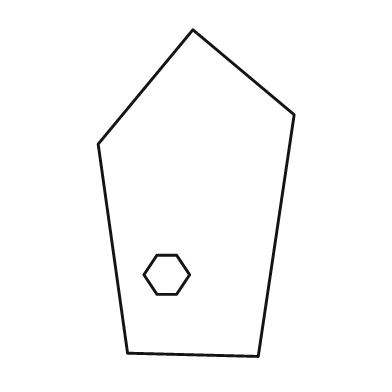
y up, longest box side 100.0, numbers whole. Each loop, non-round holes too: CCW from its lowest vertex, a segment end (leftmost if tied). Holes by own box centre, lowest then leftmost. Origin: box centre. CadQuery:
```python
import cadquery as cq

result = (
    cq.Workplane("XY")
    .moveTo(19.0, -50.0)
    .lineTo(30.0, 24.0)
    .lineTo(-1.0, 50.0)
    .lineTo(-30.0, 15.0)
    .lineTo(-21.0, -49.0)
    .close()
    .moveTo(-12.0, -31.0)
    .lineTo(-6.0, -31.0)
    .lineTo(-2.0, -25.0)
    .lineTo(-6.0, -19.0)
    .lineTo(-12.0, -19.0)
    .lineTo(-16.0, -25.0)
    .close()
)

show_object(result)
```